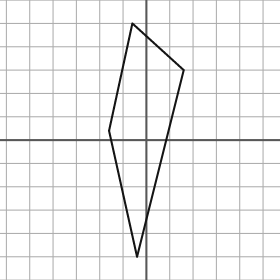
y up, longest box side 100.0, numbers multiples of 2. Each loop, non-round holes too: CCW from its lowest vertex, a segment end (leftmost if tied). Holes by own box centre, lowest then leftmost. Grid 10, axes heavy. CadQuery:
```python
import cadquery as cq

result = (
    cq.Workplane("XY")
    .moveTo(-4.0, -50.0)
    .lineTo(16.0, 30.0)
    .lineTo(-6.0, 50.0)
    .lineTo(-16.0, 4.0)
    .close()
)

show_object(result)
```